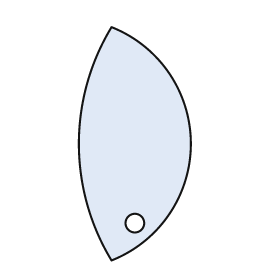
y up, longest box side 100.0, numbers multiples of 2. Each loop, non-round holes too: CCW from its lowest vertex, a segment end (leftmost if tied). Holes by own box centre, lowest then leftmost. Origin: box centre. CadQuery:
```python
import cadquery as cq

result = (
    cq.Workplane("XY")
    .moveTo(-10.0, -50.0)
    .threePointArc((24.0, 0.0), (-10.0, 50.0))
    .threePointArc((-24.0, 0.0), (-10.0, -50.0))
    .close()
    .moveTo(0.0, -34.0)
    .circle(4.0)
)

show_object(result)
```